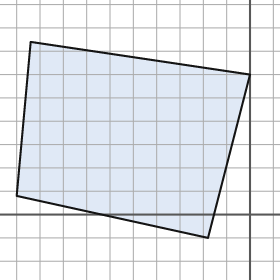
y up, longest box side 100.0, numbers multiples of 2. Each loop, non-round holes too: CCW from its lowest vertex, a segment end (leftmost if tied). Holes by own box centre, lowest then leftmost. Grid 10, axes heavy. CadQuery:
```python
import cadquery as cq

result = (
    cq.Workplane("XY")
    .moveTo(-18.0, -10.0)
    .lineTo(0.0, 60.0)
    .lineTo(-94.0, 74.0)
    .lineTo(-100.0, 8.0)
    .close()
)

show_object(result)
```